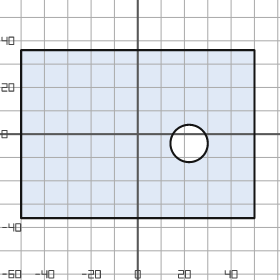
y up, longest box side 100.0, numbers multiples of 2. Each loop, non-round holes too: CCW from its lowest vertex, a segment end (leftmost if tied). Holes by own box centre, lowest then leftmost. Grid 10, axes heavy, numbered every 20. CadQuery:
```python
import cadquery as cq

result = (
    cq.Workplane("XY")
    .moveTo(-50.0, -36.0)
    .lineTo(50.0, -36.0)
    .lineTo(50.0, 36.0)
    .lineTo(-50.0, 36.0)
    .close()
    .moveTo(22.0, -4.0)
    .circle(8.0)
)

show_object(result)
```